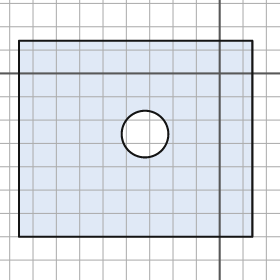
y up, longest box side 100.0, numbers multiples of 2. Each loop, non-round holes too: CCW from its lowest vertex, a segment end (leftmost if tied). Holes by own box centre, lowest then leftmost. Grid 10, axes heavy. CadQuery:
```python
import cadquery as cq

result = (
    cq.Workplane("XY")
    .moveTo(-86.0, -70.0)
    .lineTo(14.0, -70.0)
    .lineTo(14.0, 14.0)
    .lineTo(-86.0, 14.0)
    .close()
    .moveTo(-32.0, -26.0)
    .circle(10.0)
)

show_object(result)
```